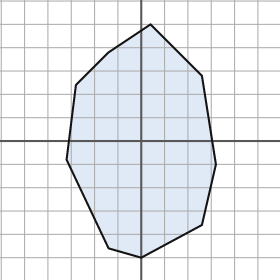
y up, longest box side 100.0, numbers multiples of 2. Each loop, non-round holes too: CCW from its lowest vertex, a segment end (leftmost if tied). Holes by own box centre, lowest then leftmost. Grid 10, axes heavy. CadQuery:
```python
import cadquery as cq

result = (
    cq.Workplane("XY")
    .moveTo(0.0, -50.0)
    .lineTo(26.0, -36.0)
    .lineTo(32.0, -10.0)
    .lineTo(26.0, 28.0)
    .lineTo(4.0, 50.0)
    .lineTo(-14.0, 38.0)
    .lineTo(-28.0, 24.0)
    .lineTo(-32.0, -8.0)
    .lineTo(-14.0, -46.0)
    .close()
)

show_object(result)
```